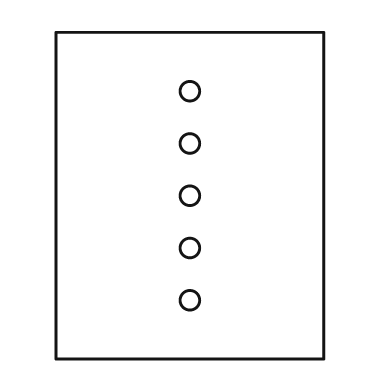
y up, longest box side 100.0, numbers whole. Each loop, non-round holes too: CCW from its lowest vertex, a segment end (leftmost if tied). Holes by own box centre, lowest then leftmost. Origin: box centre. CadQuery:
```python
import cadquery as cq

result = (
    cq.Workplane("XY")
    .moveTo(-41.0, -50.0)
    .lineTo(41.0, -50.0)
    .lineTo(41.0, 50.0)
    .lineTo(-41.0, 50.0)
    .close()
    .moveTo(0.0, -32.0)
    .circle(3.0)
    .moveTo(0.0, -16.0)
    .circle(3.0)
    .moveTo(0.0, 0.0)
    .circle(3.0)
    .moveTo(0.0, 16.0)
    .circle(3.0)
    .moveTo(0.0, 32.0)
    .circle(3.0)
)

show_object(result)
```